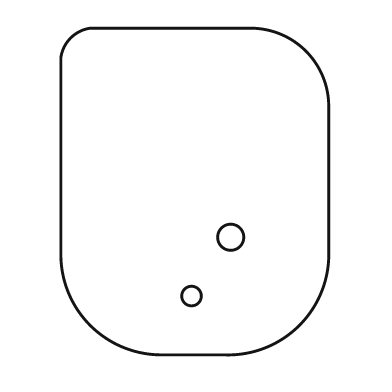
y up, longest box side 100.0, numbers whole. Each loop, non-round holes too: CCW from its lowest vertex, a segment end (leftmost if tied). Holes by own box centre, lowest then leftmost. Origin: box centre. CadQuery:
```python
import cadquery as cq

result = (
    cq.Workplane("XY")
    .moveTo(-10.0, -50.0)
    .lineTo(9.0, -50.0)
    .threePointArc((32.0, -41.0), (41.0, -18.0))
    .lineTo(41.0, 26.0)
    .threePointArc((34.0, 43.0), (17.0, 50.0))
    .lineTo(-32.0, 50.0)
    .threePointArc((-38.0, 47.0), (-41.0, 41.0))
    .lineTo(-41.0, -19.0)
    .threePointArc((-32.0, -41.0), (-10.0, -50.0))
    .close()
    .moveTo(-1.0, -32.0)
    .circle(3.0)
    .moveTo(11.0, -14.0)
    .circle(4.0)
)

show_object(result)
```